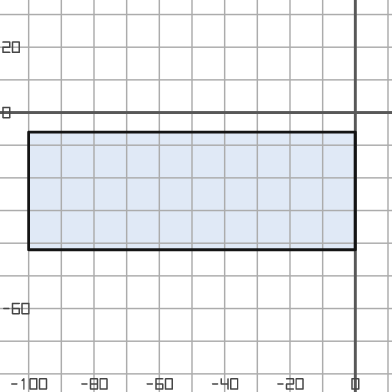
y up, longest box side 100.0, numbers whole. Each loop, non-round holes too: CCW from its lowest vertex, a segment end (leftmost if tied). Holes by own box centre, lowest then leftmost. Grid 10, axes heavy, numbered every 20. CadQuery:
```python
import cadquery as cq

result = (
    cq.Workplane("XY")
    .moveTo(-100.0, -42.0)
    .lineTo(0.0, -42.0)
    .lineTo(0.0, -6.0)
    .lineTo(-100.0, -6.0)
    .close()
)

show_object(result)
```